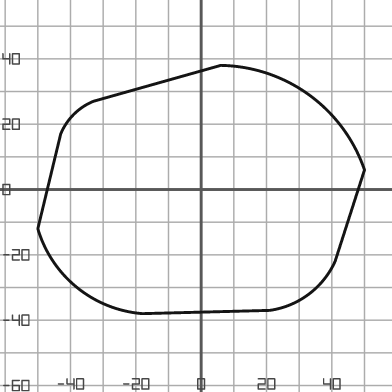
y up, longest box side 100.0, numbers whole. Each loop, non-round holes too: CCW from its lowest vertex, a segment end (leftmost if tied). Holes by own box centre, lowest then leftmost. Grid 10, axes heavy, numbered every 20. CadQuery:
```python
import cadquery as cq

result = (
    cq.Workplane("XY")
    .moveTo(-18.0, -38.0)
    .lineTo(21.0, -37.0)
    .threePointArc((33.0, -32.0), (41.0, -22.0))
    .lineTo(50.0, 6.0)
    .threePointArc((33.0, 29.0), (6.0, 38.0))
    .lineTo(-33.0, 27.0)
    .threePointArc((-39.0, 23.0), (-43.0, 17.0))
    .lineTo(-50.0, -12.0)
    .threePointArc((-38.0, -30.0), (-18.0, -38.0))
    .close()
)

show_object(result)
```